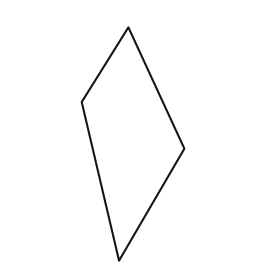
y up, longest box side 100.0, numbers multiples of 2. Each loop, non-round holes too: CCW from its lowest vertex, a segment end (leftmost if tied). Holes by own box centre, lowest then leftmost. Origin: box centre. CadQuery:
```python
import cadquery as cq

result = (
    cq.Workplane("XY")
    .moveTo(-6.0, -50.0)
    .lineTo(22.0, -2.0)
    .lineTo(-2.0, 50.0)
    .lineTo(-22.0, 18.0)
    .close()
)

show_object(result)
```